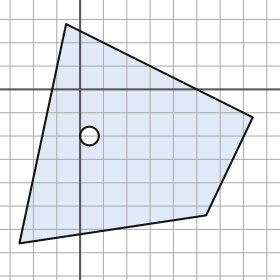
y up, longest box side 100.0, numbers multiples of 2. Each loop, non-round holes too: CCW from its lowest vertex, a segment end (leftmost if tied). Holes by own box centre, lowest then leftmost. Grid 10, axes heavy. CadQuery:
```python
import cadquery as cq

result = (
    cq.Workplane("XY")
    .moveTo(-26.0, -66.0)
    .lineTo(54.0, -54.0)
    .lineTo(74.0, -12.0)
    .lineTo(-6.0, 28.0)
    .close()
    .moveTo(4.0, -20.0)
    .circle(4.0)
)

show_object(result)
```